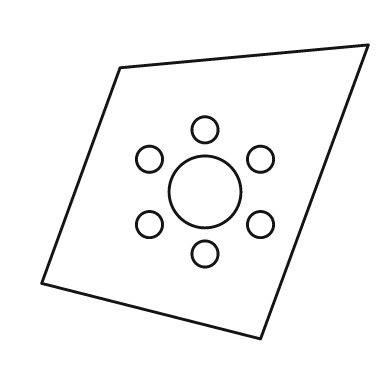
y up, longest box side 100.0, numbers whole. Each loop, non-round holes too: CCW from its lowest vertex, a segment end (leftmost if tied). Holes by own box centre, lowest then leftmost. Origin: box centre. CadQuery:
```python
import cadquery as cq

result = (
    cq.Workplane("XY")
    .moveTo(17.0, -45.0)
    .lineTo(50.0, 45.0)
    .lineTo(-26.0, 38.0)
    .lineTo(-50.0, -28.0)
    .close()
    .moveTo(0.0, -19.0)
    .circle(4.0)
    .moveTo(-17.0, -10.0)
    .circle(4.0)
    .moveTo(17.0, -10.0)
    .circle(4.0)
    .moveTo(0.0, 0.0)
    .circle(11.0)
    .moveTo(-17.0, 10.0)
    .circle(4.0)
    .moveTo(17.0, 10.0)
    .circle(4.0)
    .moveTo(0.0, 19.0)
    .circle(4.0)
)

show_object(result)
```